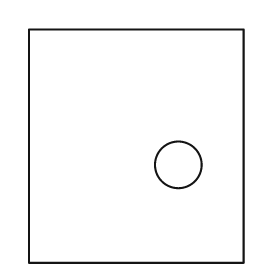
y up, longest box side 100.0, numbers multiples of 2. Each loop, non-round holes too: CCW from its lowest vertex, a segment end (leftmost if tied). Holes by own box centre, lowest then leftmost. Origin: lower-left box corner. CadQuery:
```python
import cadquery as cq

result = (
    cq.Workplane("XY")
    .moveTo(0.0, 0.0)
    .lineTo(92.0, 0.0)
    .lineTo(92.0, 100.0)
    .lineTo(0.0, 100.0)
    .close()
    .moveTo(64.0, 42.0)
    .circle(10.0)
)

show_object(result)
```